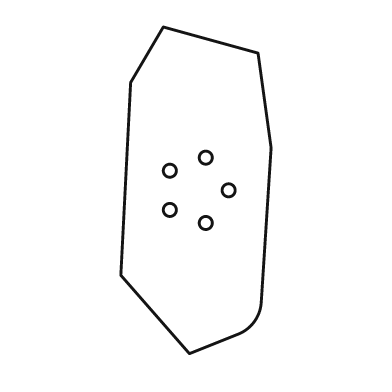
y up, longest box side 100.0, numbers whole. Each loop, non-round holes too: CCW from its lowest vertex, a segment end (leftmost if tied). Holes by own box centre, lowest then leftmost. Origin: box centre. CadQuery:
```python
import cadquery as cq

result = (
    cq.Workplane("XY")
    .moveTo(-2.0, -50.0)
    .lineTo(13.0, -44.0)
    .threePointArc((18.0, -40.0), (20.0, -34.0))
    .lineTo(23.0, 13.0)
    .lineTo(19.0, 42.0)
    .lineTo(-10.0, 50.0)
    .lineTo(-20.0, 33.0)
    .lineTo(-23.0, -26.0)
    .close()
    .moveTo(3.0, -10.0)
    .circle(2.0)
    .moveTo(-8.0, -6.0)
    .circle(2.0)
    .moveTo(10.0, 0.0)
    .circle(2.0)
    .moveTo(-8.0, 6.0)
    .circle(2.0)
    .moveTo(3.0, 10.0)
    .circle(2.0)
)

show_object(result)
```